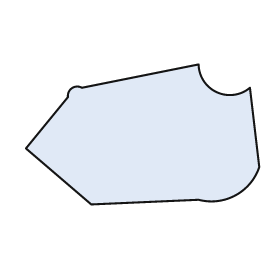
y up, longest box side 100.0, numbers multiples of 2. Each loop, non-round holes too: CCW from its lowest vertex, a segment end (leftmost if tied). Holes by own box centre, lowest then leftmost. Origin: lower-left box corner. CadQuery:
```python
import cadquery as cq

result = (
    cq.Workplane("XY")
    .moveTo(28.0, 0.0)
    .lineTo(74.0, 2.0)
    .threePointArc((90.0, 4.0), (100.0, 16.0))
    .lineTo(96.0, 50.0)
    .threePointArc((82.0, 48.0), (74.0, 60.0))
    .lineTo(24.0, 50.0)
    .threePointArc((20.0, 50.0), (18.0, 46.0))
    .lineTo(0.0, 24.0)
    .close()
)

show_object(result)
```